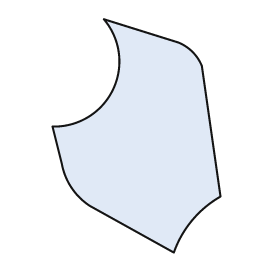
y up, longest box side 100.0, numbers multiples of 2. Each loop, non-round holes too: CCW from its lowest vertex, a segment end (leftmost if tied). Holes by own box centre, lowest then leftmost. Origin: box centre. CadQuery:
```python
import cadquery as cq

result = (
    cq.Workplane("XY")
    .moveTo(16.0, -50.0)
    .threePointArc((24.0, -36.0), (36.0, -26.0))
    .lineTo(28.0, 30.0)
    .threePointArc((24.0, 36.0), (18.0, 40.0))
    .lineTo(-14.0, 50.0)
    .threePointArc((-10.0, 20.0), (-36.0, 4.0))
    .lineTo(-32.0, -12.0)
    .threePointArc((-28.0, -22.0), (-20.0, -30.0))
    .close()
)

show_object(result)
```